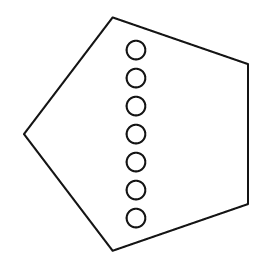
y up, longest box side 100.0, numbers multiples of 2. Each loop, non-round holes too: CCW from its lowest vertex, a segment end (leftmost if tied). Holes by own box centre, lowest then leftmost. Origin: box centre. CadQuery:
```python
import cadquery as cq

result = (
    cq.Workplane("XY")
    .moveTo(-10.0, -50.0)
    .lineTo(48.0, -30.0)
    .lineTo(48.0, 30.0)
    .lineTo(-10.0, 50.0)
    .lineTo(-48.0, 0.0)
    .close()
    .moveTo(0.0, -36.0)
    .circle(4.0)
    .moveTo(0.0, -24.0)
    .circle(4.0)
    .moveTo(0.0, -12.0)
    .circle(4.0)
    .moveTo(0.0, 0.0)
    .circle(4.0)
    .moveTo(0.0, 12.0)
    .circle(4.0)
    .moveTo(0.0, 24.0)
    .circle(4.0)
    .moveTo(0.0, 36.0)
    .circle(4.0)
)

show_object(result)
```